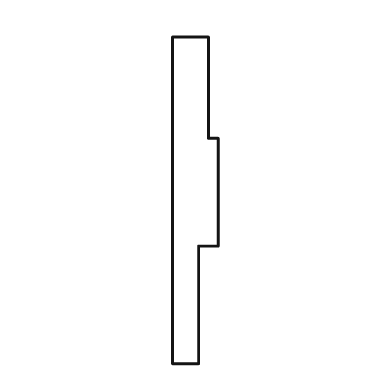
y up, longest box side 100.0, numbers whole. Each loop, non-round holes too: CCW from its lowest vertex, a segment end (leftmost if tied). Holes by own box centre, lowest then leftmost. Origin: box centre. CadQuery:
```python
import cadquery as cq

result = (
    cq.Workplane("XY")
    .moveTo(-7.0, -50.0)
    .lineTo(1.0, -50.0)
    .lineTo(1.0, -14.0)
    .lineTo(7.0, -14.0)
    .lineTo(7.0, 19.0)
    .lineTo(4.0, 19.0)
    .lineTo(4.0, 50.0)
    .lineTo(-7.0, 50.0)
    .close()
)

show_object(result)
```